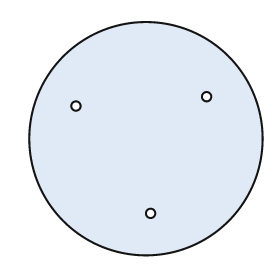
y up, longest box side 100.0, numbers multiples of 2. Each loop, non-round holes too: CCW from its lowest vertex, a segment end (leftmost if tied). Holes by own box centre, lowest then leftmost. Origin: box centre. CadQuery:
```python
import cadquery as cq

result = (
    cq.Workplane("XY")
    .moveTo(0.0, 0.0)
    .circle(50.0)
    .moveTo(2.0, -32.0)
    .circle(2.0)
    .moveTo(-30.0, 14.0)
    .circle(2.0)
    .moveTo(26.0, 18.0)
    .circle(2.0)
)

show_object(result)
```